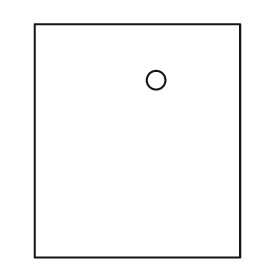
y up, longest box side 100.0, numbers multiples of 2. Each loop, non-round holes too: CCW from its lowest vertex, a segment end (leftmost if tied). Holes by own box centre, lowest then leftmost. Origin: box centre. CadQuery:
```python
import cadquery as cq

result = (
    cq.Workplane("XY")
    .moveTo(-44.0, -50.0)
    .lineTo(44.0, -50.0)
    .lineTo(44.0, 50.0)
    .lineTo(-44.0, 50.0)
    .close()
    .moveTo(8.0, 26.0)
    .circle(4.0)
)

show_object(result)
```